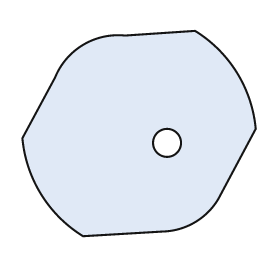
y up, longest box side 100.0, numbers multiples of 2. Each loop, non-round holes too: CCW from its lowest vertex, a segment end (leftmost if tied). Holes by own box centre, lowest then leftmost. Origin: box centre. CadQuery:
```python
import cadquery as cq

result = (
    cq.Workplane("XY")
    .moveTo(-24.0, -44.0)
    .lineTo(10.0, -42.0)
    .threePointArc((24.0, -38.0), (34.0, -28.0))
    .lineTo(50.0, 2.0)
    .threePointArc((42.0, 26.0), (24.0, 44.0))
    .lineTo(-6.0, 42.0)
    .threePointArc((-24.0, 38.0), (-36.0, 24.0))
    .lineTo(-50.0, -2.0)
    .threePointArc((-42.0, -26.0), (-24.0, -44.0))
    .close()
    .moveTo(12.0, -4.0)
    .circle(6.0)
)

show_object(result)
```